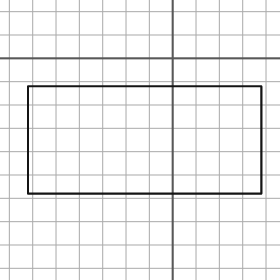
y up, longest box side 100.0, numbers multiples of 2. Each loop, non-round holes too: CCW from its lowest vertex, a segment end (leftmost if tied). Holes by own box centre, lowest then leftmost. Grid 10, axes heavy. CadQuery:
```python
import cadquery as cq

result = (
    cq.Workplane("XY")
    .moveTo(-62.0, -58.0)
    .lineTo(38.0, -58.0)
    .lineTo(38.0, -12.0)
    .lineTo(-62.0, -12.0)
    .close()
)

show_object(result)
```